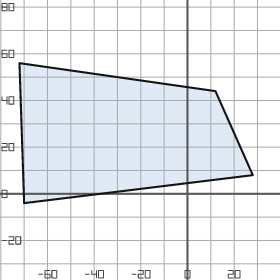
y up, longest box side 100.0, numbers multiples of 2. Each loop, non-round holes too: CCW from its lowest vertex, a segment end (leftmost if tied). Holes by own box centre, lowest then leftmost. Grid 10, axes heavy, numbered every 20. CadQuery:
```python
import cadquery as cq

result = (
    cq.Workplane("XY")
    .moveTo(-70.0, -4.0)
    .lineTo(28.0, 8.0)
    .lineTo(12.0, 44.0)
    .lineTo(-72.0, 56.0)
    .close()
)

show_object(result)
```